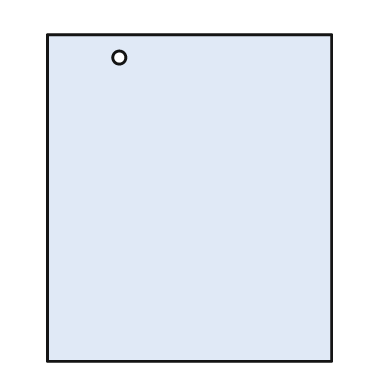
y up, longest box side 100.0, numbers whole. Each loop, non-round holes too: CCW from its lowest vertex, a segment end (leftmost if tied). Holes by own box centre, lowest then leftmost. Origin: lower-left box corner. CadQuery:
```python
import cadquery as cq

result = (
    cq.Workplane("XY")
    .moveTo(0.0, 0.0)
    .lineTo(87.0, 0.0)
    .lineTo(87.0, 100.0)
    .lineTo(0.0, 100.0)
    .close()
    .moveTo(22.0, 93.0)
    .circle(2.0)
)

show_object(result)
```